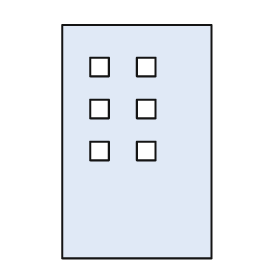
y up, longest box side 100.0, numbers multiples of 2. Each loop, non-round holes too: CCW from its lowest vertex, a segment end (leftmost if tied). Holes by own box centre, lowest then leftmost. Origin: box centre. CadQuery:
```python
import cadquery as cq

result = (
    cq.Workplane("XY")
    .moveTo(-32.0, -50.0)
    .lineTo(32.0, -50.0)
    .lineTo(32.0, 50.0)
    .lineTo(-32.0, 50.0)
    .close()
    .moveTo(-20.0, -8.0)
    .lineTo(-12.0, -8.0)
    .lineTo(-12.0, 0.0)
    .lineTo(-20.0, 0.0)
    .close()
    .moveTo(0.0, -8.0)
    .lineTo(8.0, -8.0)
    .lineTo(8.0, 0.0)
    .lineTo(0.0, 0.0)
    .close()
    .moveTo(-20.0, 10.0)
    .lineTo(-12.0, 10.0)
    .lineTo(-12.0, 18.0)
    .lineTo(-20.0, 18.0)
    .close()
    .moveTo(0.0, 10.0)
    .lineTo(8.0, 10.0)
    .lineTo(8.0, 18.0)
    .lineTo(0.0, 18.0)
    .close()
    .moveTo(-20.0, 28.0)
    .lineTo(-12.0, 28.0)
    .lineTo(-12.0, 36.0)
    .lineTo(-20.0, 36.0)
    .close()
    .moveTo(0.0, 28.0)
    .lineTo(8.0, 28.0)
    .lineTo(8.0, 36.0)
    .lineTo(0.0, 36.0)
    .close()
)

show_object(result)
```